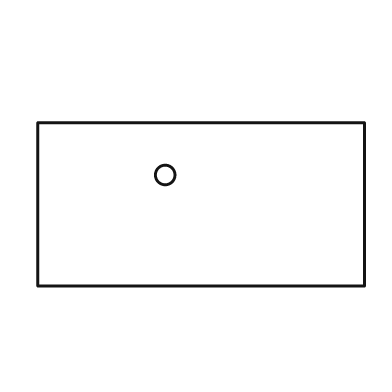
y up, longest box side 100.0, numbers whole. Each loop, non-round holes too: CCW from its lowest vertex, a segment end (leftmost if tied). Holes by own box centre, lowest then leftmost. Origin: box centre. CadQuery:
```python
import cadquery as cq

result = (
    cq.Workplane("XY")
    .moveTo(-50.0, -25.0)
    .lineTo(50.0, -25.0)
    .lineTo(50.0, 25.0)
    .lineTo(-50.0, 25.0)
    .close()
    .moveTo(-11.0, 9.0)
    .circle(3.0)
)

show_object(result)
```